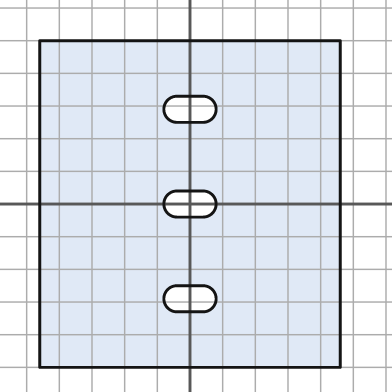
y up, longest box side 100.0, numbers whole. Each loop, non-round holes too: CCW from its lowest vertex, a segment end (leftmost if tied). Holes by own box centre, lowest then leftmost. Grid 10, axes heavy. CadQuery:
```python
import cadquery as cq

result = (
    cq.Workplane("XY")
    .moveTo(-46.0, -50.0)
    .lineTo(46.0, -50.0)
    .lineTo(46.0, 50.0)
    .lineTo(-46.0, 50.0)
    .close()
    .moveTo(-4.0, -33.0)
    .lineTo(4.0, -33.0)
    .threePointArc((8.0, -29.0), (4.0, -25.0))
    .lineTo(-4.0, -25.0)
    .threePointArc((-8.0, -29.0), (-4.0, -33.0))
    .close()
    .moveTo(-4.0, -4.0)
    .lineTo(4.0, -4.0)
    .threePointArc((8.0, 0.0), (4.0, 4.0))
    .lineTo(-4.0, 4.0)
    .threePointArc((-8.0, 0.0), (-4.0, -4.0))
    .close()
    .moveTo(-4.0, 25.0)
    .lineTo(4.0, 25.0)
    .threePointArc((8.0, 29.0), (4.0, 33.0))
    .lineTo(-4.0, 33.0)
    .threePointArc((-8.0, 29.0), (-4.0, 25.0))
    .close()
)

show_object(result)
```